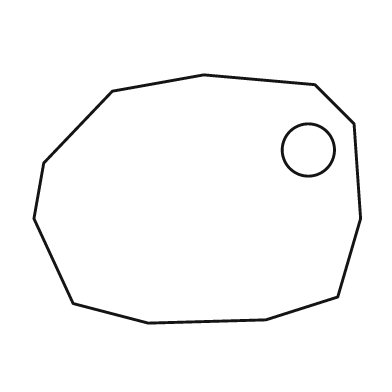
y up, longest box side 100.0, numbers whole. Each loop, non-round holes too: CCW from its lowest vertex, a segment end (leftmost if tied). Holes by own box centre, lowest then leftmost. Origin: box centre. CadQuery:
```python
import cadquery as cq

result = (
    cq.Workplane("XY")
    .moveTo(-15.0, -38.0)
    .lineTo(21.0, -37.0)
    .lineTo(43.0, -30.0)
    .lineTo(50.0, -6.0)
    .lineTo(48.0, 23.0)
    .lineTo(36.0, 35.0)
    .lineTo(2.0, 38.0)
    .lineTo(-26.0, 33.0)
    .lineTo(-47.0, 11.0)
    .lineTo(-50.0, -6.0)
    .lineTo(-38.0, -32.0)
    .close()
    .moveTo(34.0, 15.0)
    .circle(8.0)
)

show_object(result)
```